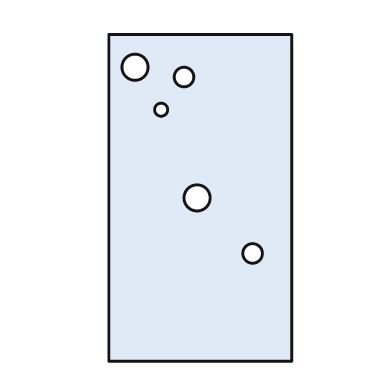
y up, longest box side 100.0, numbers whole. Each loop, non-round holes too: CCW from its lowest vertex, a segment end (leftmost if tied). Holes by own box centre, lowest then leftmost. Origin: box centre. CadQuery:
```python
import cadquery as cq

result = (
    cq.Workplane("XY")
    .moveTo(-28.0, -50.0)
    .lineTo(28.0, -50.0)
    .lineTo(28.0, 50.0)
    .lineTo(-28.0, 50.0)
    .close()
    .moveTo(16.0, -17.0)
    .circle(3.0)
    .moveTo(-1.0, 0.0)
    .circle(4.0)
    .moveTo(-12.0, 27.0)
    .circle(2.0)
    .moveTo(-5.0, 37.0)
    .circle(3.0)
    .moveTo(-20.0, 40.0)
    .circle(4.0)
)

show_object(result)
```